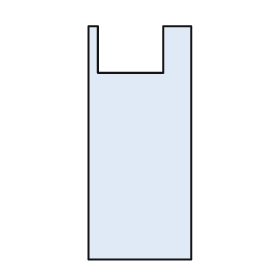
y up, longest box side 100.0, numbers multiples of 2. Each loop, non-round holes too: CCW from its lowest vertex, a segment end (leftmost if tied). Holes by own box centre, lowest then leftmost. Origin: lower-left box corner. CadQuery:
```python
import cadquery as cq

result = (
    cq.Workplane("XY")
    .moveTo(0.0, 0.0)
    .lineTo(44.0, 0.0)
    .lineTo(44.0, 100.0)
    .lineTo(32.0, 100.0)
    .lineTo(32.0, 80.0)
    .lineTo(4.0, 80.0)
    .lineTo(4.0, 100.0)
    .lineTo(0.0, 100.0)
    .close()
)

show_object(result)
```